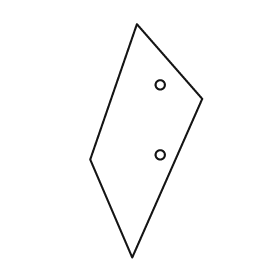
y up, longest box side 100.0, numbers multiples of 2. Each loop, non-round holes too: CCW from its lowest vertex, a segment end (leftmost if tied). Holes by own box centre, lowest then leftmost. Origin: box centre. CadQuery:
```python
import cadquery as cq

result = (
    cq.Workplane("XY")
    .moveTo(-6.0, -50.0)
    .lineTo(24.0, 18.0)
    .lineTo(-4.0, 50.0)
    .lineTo(-24.0, -8.0)
    .close()
    .moveTo(6.0, -6.0)
    .circle(2.0)
    .moveTo(6.0, 24.0)
    .circle(2.0)
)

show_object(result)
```